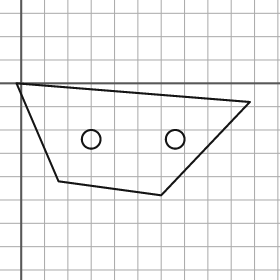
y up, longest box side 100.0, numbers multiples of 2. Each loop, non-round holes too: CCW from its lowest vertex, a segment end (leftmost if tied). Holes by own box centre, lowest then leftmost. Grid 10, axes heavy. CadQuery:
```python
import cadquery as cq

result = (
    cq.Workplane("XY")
    .moveTo(60.0, -48.0)
    .lineTo(98.0, -8.0)
    .lineTo(-2.0, 0.0)
    .lineTo(16.0, -42.0)
    .close()
    .moveTo(30.0, -24.0)
    .circle(4.0)
    .moveTo(66.0, -24.0)
    .circle(4.0)
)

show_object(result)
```